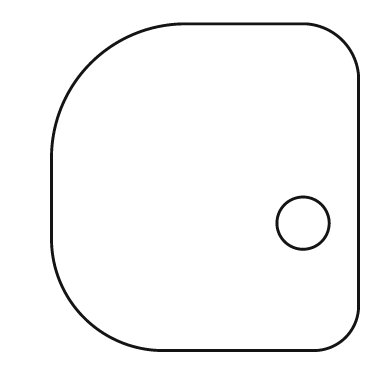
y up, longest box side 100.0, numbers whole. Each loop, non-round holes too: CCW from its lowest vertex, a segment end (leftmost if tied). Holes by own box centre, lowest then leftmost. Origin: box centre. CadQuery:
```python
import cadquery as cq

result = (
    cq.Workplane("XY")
    .moveTo(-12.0, -50.0)
    .lineTo(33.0, -50.0)
    .threePointArc((43.0, -46.0), (47.0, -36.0))
    .lineTo(47.0, 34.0)
    .threePointArc((42.0, 45.0), (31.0, 50.0))
    .lineTo(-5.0, 50.0)
    .threePointArc((-35.0, 38.0), (-47.0, 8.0))
    .lineTo(-47.0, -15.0)
    .threePointArc((-37.0, -40.0), (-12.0, -50.0))
    .close()
    .moveTo(30.0, -11.0)
    .circle(8.0)
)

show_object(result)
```